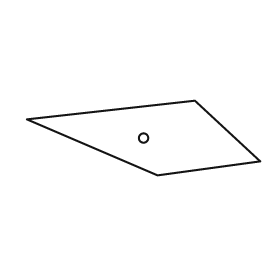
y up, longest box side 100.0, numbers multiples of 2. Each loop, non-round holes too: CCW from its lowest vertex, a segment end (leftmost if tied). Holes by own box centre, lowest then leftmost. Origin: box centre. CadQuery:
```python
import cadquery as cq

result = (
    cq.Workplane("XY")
    .moveTo(6.0, -16.0)
    .lineTo(50.0, -10.0)
    .lineTo(22.0, 16.0)
    .lineTo(-50.0, 8.0)
    .close()
    .moveTo(0.0, 0.0)
    .circle(2.0)
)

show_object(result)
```